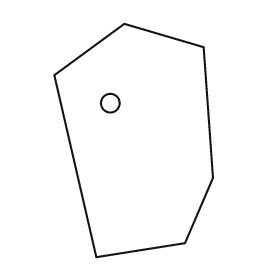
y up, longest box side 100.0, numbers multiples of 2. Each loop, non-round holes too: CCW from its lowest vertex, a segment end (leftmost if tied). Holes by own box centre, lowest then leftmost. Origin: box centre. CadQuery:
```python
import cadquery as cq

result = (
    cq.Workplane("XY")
    .moveTo(-16.0, -50.0)
    .lineTo(22.0, -44.0)
    .lineTo(34.0, -16.0)
    .lineTo(30.0, 40.0)
    .lineTo(-4.0, 50.0)
    .lineTo(-34.0, 28.0)
    .close()
    .moveTo(-10.0, 16.0)
    .circle(4.0)
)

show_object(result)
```